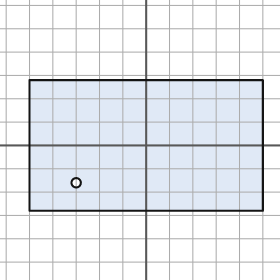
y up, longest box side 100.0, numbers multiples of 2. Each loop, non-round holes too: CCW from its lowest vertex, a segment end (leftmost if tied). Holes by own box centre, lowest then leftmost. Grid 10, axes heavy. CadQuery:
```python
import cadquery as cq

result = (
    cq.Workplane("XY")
    .moveTo(-50.0, -28.0)
    .lineTo(50.0, -28.0)
    .lineTo(50.0, 28.0)
    .lineTo(-50.0, 28.0)
    .close()
    .moveTo(-30.0, -16.0)
    .circle(2.0)
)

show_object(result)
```